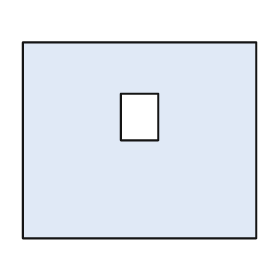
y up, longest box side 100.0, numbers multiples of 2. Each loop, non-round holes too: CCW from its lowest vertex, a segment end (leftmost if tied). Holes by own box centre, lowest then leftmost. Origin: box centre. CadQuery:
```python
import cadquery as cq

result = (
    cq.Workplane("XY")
    .moveTo(-50.0, -42.0)
    .lineTo(50.0, -42.0)
    .lineTo(50.0, 42.0)
    .lineTo(-50.0, 42.0)
    .close()
    .moveTo(-8.0, 0.0)
    .lineTo(8.0, 0.0)
    .lineTo(8.0, 20.0)
    .lineTo(-8.0, 20.0)
    .close()
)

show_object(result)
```